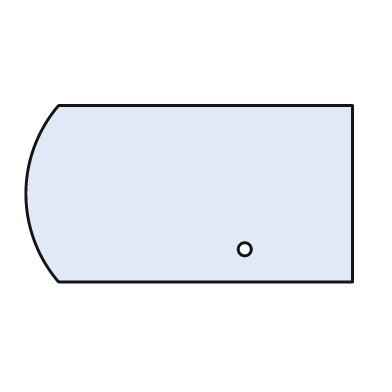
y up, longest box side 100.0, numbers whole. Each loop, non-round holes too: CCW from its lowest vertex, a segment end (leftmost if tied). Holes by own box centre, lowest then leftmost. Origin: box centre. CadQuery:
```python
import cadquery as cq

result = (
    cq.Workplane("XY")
    .moveTo(-40.0, -27.0)
    .lineTo(50.0, -27.0)
    .lineTo(50.0, 27.0)
    .lineTo(-40.0, 27.0)
    .threePointArc((-50.0, 0.0), (-40.0, -27.0))
    .close()
    .moveTo(17.0, -17.0)
    .circle(2.0)
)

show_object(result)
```